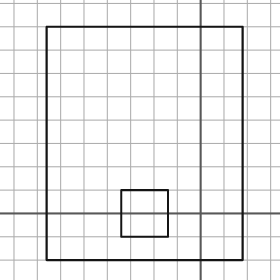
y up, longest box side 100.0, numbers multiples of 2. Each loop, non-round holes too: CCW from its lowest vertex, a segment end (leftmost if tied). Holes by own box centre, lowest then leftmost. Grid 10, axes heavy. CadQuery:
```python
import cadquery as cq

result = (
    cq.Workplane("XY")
    .moveTo(-66.0, -20.0)
    .lineTo(18.0, -20.0)
    .lineTo(18.0, 80.0)
    .lineTo(-66.0, 80.0)
    .close()
    .moveTo(-34.0, -10.0)
    .lineTo(-14.0, -10.0)
    .lineTo(-14.0, 10.0)
    .lineTo(-34.0, 10.0)
    .close()
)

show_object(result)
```